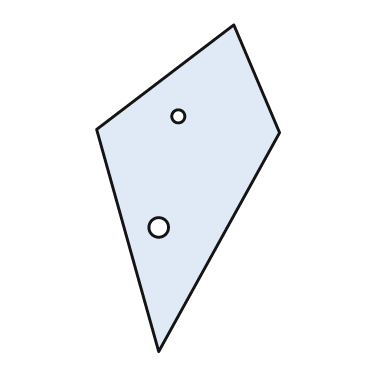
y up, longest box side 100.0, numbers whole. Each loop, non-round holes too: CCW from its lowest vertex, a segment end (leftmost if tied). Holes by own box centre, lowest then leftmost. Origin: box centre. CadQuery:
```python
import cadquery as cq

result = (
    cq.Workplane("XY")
    .moveTo(-9.0, -50.0)
    .lineTo(28.0, 17.0)
    .lineTo(14.0, 50.0)
    .lineTo(-28.0, 18.0)
    .close()
    .moveTo(-9.0, -12.0)
    .circle(3.0)
    .moveTo(-3.0, 22.0)
    .circle(2.0)
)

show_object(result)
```